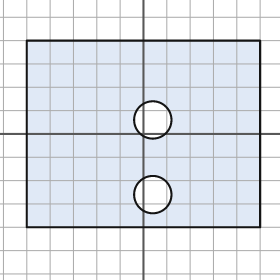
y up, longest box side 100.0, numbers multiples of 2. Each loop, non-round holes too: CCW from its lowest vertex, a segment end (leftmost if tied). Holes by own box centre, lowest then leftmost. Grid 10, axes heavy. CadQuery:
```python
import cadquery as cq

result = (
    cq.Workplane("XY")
    .moveTo(-50.0, -40.0)
    .lineTo(50.0, -40.0)
    .lineTo(50.0, 40.0)
    .lineTo(-50.0, 40.0)
    .close()
    .moveTo(4.0, -26.0)
    .circle(8.0)
    .moveTo(4.0, 6.0)
    .circle(8.0)
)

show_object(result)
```